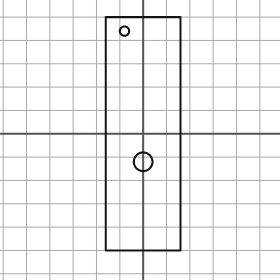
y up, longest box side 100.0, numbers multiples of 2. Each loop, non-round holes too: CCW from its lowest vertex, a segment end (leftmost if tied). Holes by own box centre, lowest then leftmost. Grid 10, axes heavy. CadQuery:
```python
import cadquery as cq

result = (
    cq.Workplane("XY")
    .moveTo(-16.0, -50.0)
    .lineTo(16.0, -50.0)
    .lineTo(16.0, 50.0)
    .lineTo(-16.0, 50.0)
    .close()
    .moveTo(0.0, -12.0)
    .circle(4.0)
    .moveTo(-8.0, 44.0)
    .circle(2.0)
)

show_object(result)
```